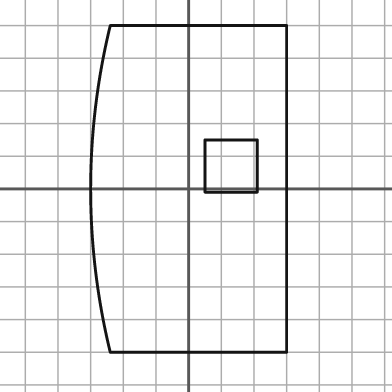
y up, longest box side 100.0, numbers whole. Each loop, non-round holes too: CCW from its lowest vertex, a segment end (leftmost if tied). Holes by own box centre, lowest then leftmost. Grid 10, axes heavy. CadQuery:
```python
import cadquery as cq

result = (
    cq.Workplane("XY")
    .moveTo(-24.0, -50.0)
    .lineTo(30.0, -50.0)
    .lineTo(30.0, 50.0)
    .lineTo(-24.0, 50.0)
    .threePointArc((-30.0, 0.0), (-24.0, -50.0))
    .close()
    .moveTo(5.0, -1.0)
    .lineTo(21.0, -1.0)
    .lineTo(21.0, 15.0)
    .lineTo(5.0, 15.0)
    .close()
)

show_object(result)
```